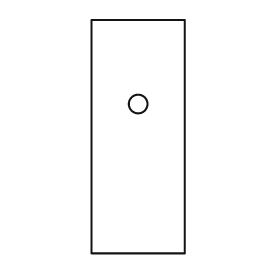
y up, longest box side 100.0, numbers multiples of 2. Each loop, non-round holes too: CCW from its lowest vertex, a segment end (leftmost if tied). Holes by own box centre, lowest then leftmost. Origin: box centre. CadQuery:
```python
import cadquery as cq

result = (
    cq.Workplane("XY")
    .moveTo(-20.0, -50.0)
    .lineTo(20.0, -50.0)
    .lineTo(20.0, 50.0)
    .lineTo(-20.0, 50.0)
    .close()
    .moveTo(0.0, 14.0)
    .circle(4.0)
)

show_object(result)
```